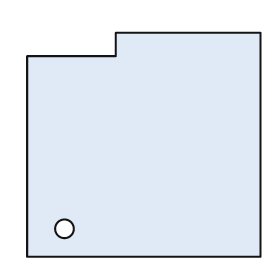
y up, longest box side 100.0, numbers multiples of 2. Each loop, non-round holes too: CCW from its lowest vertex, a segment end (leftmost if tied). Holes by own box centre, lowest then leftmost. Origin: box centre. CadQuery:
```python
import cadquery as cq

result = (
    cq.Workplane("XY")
    .moveTo(-50.0, -48.0)
    .lineTo(50.0, -48.0)
    .lineTo(50.0, 48.0)
    .lineTo(-12.0, 48.0)
    .lineTo(-12.0, 38.0)
    .lineTo(-50.0, 38.0)
    .close()
    .moveTo(-34.0, -36.0)
    .circle(4.0)
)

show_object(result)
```